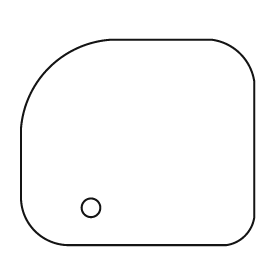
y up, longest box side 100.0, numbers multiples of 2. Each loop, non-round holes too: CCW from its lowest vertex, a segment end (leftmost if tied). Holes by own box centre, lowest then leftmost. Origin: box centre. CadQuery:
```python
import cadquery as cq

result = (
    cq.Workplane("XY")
    .moveTo(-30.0, -44.0)
    .lineTo(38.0, -44.0)
    .threePointArc((46.0, -40.0), (50.0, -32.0))
    .lineTo(50.0, 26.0)
    .threePointArc((44.0, 38.0), (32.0, 44.0))
    .lineTo(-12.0, 44.0)
    .threePointArc((-38.0, 32.0), (-50.0, 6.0))
    .lineTo(-50.0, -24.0)
    .threePointArc((-44.0, -38.0), (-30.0, -44.0))
    .close()
    .moveTo(-20.0, -28.0)
    .circle(4.0)
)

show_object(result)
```